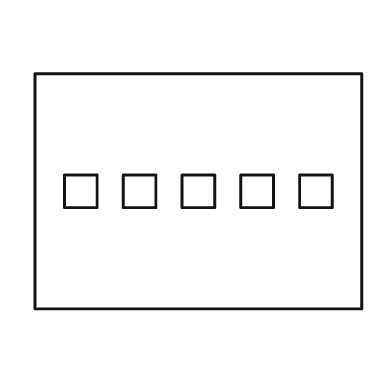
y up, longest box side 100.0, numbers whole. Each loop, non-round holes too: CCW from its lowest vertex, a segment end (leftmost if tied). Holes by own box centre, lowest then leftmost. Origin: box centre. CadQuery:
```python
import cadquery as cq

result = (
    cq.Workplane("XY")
    .moveTo(-50.0, -36.0)
    .lineTo(50.0, -36.0)
    .lineTo(50.0, 36.0)
    .lineTo(-50.0, 36.0)
    .close()
    .moveTo(-41.0, -5.0)
    .lineTo(-31.0, -5.0)
    .lineTo(-31.0, 5.0)
    .lineTo(-41.0, 5.0)
    .close()
    .moveTo(-23.0, -5.0)
    .lineTo(-13.0, -5.0)
    .lineTo(-13.0, 5.0)
    .lineTo(-23.0, 5.0)
    .close()
    .moveTo(-5.0, -5.0)
    .lineTo(5.0, -5.0)
    .lineTo(5.0, 5.0)
    .lineTo(-5.0, 5.0)
    .close()
    .moveTo(13.0, -5.0)
    .lineTo(23.0, -5.0)
    .lineTo(23.0, 5.0)
    .lineTo(13.0, 5.0)
    .close()
    .moveTo(31.0, -5.0)
    .lineTo(41.0, -5.0)
    .lineTo(41.0, 5.0)
    .lineTo(31.0, 5.0)
    .close()
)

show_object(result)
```